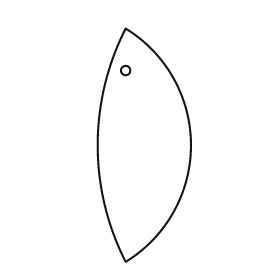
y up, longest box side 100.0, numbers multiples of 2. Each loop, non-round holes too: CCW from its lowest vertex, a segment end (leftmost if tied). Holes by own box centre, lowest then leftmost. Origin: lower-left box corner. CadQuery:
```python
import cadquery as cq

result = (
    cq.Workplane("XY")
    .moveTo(12.0, 0.0)
    .threePointArc((40.0, 50.0), (12.0, 100.0))
    .threePointArc((0.0, 50.0), (12.0, 0.0))
    .close()
    .moveTo(12.0, 82.0)
    .circle(2.0)
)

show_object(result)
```